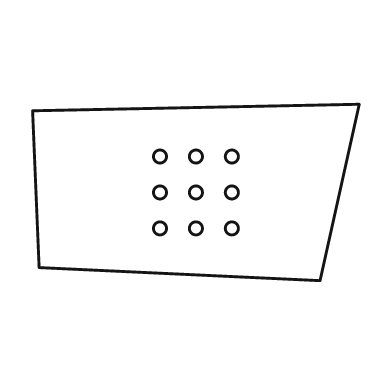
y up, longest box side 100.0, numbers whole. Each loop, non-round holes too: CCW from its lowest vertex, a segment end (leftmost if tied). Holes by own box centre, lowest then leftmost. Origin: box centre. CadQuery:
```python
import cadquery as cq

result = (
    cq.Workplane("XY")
    .moveTo(38.0, -27.0)
    .lineTo(50.0, 27.0)
    .lineTo(-50.0, 25.0)
    .lineTo(-48.0, -23.0)
    .close()
    .moveTo(-11.0, -11.0)
    .circle(2.0)
    .moveTo(0.0, -11.0)
    .circle(2.0)
    .moveTo(11.0, -11.0)
    .circle(2.0)
    .moveTo(-11.0, 0.0)
    .circle(2.0)
    .moveTo(0.0, 0.0)
    .circle(2.0)
    .moveTo(11.0, 0.0)
    .circle(2.0)
    .moveTo(-11.0, 11.0)
    .circle(2.0)
    .moveTo(0.0, 11.0)
    .circle(2.0)
    .moveTo(11.0, 11.0)
    .circle(2.0)
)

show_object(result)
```